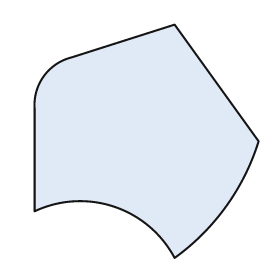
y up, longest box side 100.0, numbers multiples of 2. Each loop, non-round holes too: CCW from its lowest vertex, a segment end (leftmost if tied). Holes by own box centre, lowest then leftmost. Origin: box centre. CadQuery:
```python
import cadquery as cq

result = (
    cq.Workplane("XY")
    .moveTo(12.0, -50.0)
    .threePointArc((34.0, -28.0), (48.0, 0.0))
    .lineTo(12.0, 50.0)
    .lineTo(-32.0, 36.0)
    .threePointArc((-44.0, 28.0), (-48.0, 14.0))
    .lineTo(-48.0, -30.0)
    .threePointArc((-14.0, -28.0), (12.0, -50.0))
    .close()
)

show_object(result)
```